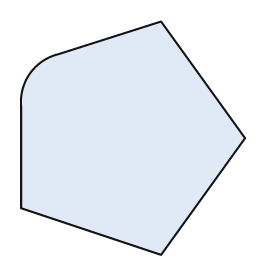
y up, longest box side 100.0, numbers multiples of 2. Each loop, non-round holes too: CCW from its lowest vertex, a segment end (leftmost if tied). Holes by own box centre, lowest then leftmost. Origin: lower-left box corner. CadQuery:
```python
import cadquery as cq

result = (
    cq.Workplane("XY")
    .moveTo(60.0, 0.0)
    .lineTo(96.0, 50.0)
    .lineTo(60.0, 100.0)
    .lineTo(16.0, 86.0)
    .threePointArc((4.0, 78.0), (0.0, 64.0))
    .lineTo(0.0, 20.0)
    .close()
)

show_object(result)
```